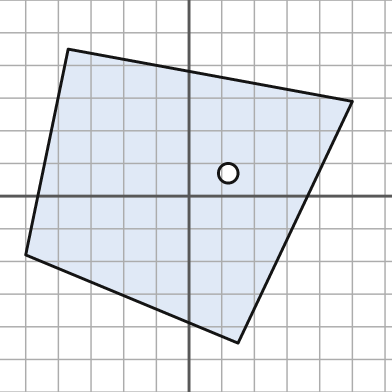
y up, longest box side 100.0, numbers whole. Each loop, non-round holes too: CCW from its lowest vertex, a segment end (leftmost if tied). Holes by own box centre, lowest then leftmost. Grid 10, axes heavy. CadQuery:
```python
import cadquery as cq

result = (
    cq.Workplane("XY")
    .moveTo(15.0, -45.0)
    .lineTo(50.0, 29.0)
    .lineTo(-37.0, 45.0)
    .lineTo(-50.0, -18.0)
    .close()
    .moveTo(12.0, 7.0)
    .circle(3.0)
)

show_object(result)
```